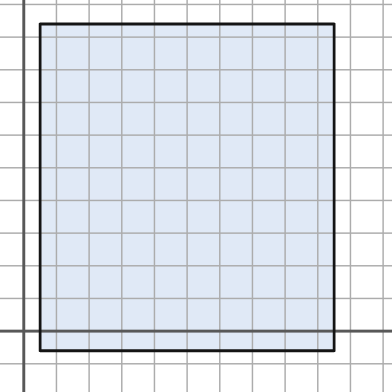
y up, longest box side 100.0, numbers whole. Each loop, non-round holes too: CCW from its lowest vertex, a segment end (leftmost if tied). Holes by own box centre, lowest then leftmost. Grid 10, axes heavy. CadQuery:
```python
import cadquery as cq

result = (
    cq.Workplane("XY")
    .moveTo(5.0, -6.0)
    .lineTo(95.0, -6.0)
    .lineTo(95.0, 94.0)
    .lineTo(5.0, 94.0)
    .close()
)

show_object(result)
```